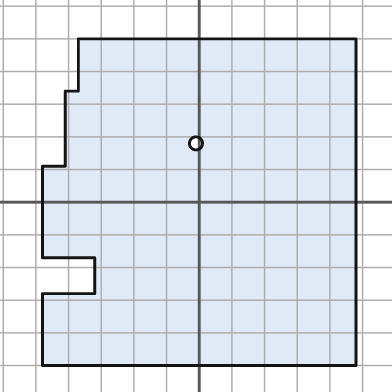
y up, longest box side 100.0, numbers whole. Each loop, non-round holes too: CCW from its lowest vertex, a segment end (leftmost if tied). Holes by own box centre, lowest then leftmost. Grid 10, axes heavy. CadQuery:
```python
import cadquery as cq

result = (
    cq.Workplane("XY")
    .moveTo(-48.0, -50.0)
    .lineTo(48.0, -50.0)
    .lineTo(48.0, 50.0)
    .lineTo(-37.0, 50.0)
    .lineTo(-37.0, 34.0)
    .lineTo(-41.0, 34.0)
    .lineTo(-41.0, 11.0)
    .lineTo(-48.0, 11.0)
    .lineTo(-48.0, -17.0)
    .lineTo(-32.0, -17.0)
    .lineTo(-32.0, -28.0)
    .lineTo(-48.0, -28.0)
    .close()
    .moveTo(-1.0, 18.0)
    .circle(2.0)
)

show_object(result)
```